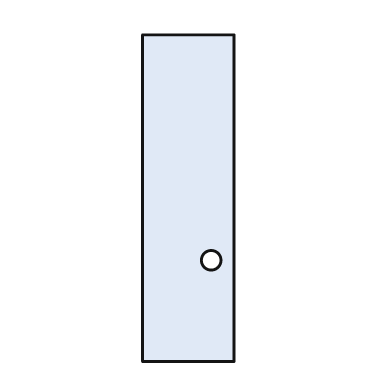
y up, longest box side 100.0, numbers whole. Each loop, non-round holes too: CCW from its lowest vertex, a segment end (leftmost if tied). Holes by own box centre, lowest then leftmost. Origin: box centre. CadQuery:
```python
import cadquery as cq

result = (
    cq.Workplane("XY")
    .moveTo(-14.0, -50.0)
    .lineTo(14.0, -50.0)
    .lineTo(14.0, 50.0)
    .lineTo(-14.0, 50.0)
    .close()
    .moveTo(7.0, -19.0)
    .circle(3.0)
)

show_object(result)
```